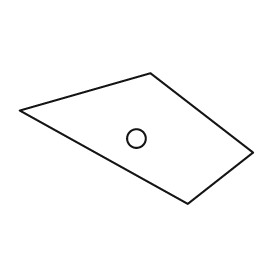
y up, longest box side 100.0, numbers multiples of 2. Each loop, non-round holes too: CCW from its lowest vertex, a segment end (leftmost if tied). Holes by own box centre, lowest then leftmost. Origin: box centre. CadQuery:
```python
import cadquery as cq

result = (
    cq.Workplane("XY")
    .moveTo(22.0, -28.0)
    .lineTo(50.0, -6.0)
    .lineTo(6.0, 28.0)
    .lineTo(-50.0, 12.0)
    .close()
    .moveTo(0.0, 0.0)
    .circle(4.0)
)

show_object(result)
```